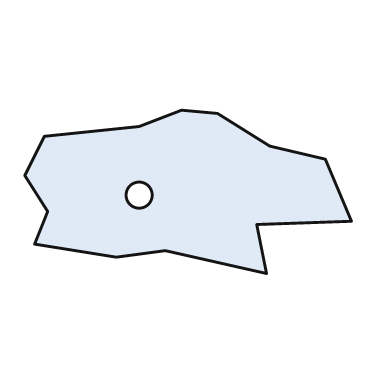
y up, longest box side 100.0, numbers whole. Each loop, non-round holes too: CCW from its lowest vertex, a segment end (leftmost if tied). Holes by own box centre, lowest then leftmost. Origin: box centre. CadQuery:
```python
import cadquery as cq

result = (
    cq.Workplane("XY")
    .moveTo(24.0, -25.0)
    .lineTo(21.0, -10.0)
    .lineTo(50.0, -9.0)
    .lineTo(42.0, 10.0)
    .lineTo(25.0, 14.0)
    .lineTo(9.0, 24.0)
    .lineTo(-2.0, 25.0)
    .lineTo(-15.0, 20.0)
    .lineTo(-44.0, 17.0)
    .lineTo(-50.0, 5.0)
    .lineTo(-43.0, -6.0)
    .lineTo(-47.0, -16.0)
    .lineTo(-22.0, -20.0)
    .lineTo(-7.0, -18.0)
    .close()
    .moveTo(-15.0, -1.0)
    .circle(4.0)
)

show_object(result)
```